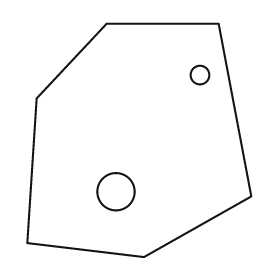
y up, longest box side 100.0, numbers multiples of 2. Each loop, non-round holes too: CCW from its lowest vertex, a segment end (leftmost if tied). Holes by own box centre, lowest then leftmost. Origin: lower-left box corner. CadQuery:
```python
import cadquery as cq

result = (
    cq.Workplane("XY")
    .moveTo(50.0, 0.0)
    .lineTo(96.0, 26.0)
    .lineTo(82.0, 100.0)
    .lineTo(34.0, 100.0)
    .lineTo(4.0, 68.0)
    .lineTo(0.0, 6.0)
    .close()
    .moveTo(38.0, 28.0)
    .circle(8.0)
    .moveTo(74.0, 78.0)
    .circle(4.0)
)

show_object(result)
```